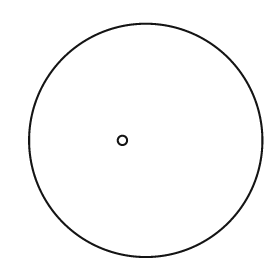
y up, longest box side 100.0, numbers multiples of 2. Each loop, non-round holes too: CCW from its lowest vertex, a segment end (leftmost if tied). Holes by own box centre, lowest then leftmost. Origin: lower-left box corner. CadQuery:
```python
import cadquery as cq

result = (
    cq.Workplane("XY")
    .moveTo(50.0, 50.0)
    .circle(50.0)
    .moveTo(40.0, 50.0)
    .circle(2.0)
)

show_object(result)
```